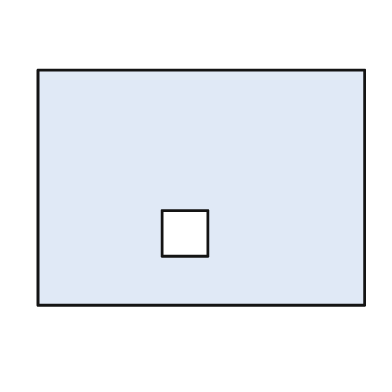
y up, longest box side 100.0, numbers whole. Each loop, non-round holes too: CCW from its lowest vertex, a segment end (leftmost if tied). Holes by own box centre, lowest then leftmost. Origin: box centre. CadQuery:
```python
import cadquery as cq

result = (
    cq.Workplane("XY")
    .moveTo(-50.0, -36.0)
    .lineTo(50.0, -36.0)
    .lineTo(50.0, 36.0)
    .lineTo(-50.0, 36.0)
    .close()
    .moveTo(-12.0, -21.0)
    .lineTo(2.0, -21.0)
    .lineTo(2.0, -7.0)
    .lineTo(-12.0, -7.0)
    .close()
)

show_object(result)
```